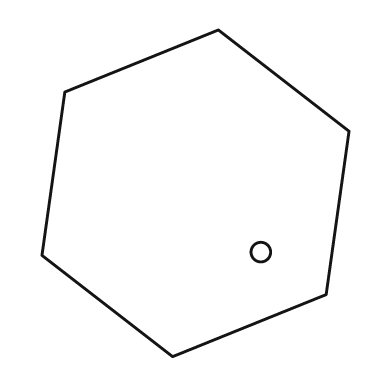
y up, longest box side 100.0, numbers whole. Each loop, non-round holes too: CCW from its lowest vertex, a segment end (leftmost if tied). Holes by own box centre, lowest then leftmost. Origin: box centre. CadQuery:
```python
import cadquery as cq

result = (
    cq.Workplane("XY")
    .moveTo(-7.0, -50.0)
    .lineTo(40.0, -31.0)
    .lineTo(47.0, 19.0)
    .lineTo(7.0, 50.0)
    .lineTo(-40.0, 31.0)
    .lineTo(-47.0, -19.0)
    .close()
    .moveTo(20.0, -18.0)
    .circle(3.0)
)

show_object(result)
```